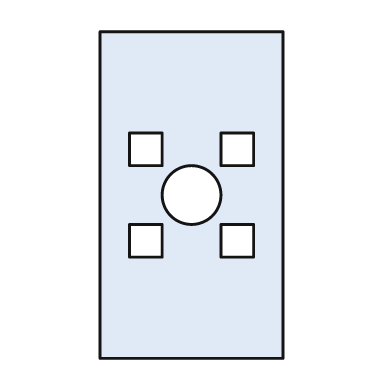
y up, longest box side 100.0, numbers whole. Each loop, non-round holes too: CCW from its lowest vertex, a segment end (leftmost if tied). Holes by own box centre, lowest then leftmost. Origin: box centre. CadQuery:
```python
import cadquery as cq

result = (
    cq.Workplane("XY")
    .moveTo(-28.0, -50.0)
    .lineTo(28.0, -50.0)
    .lineTo(28.0, 50.0)
    .lineTo(-28.0, 50.0)
    .close()
    .moveTo(-19.0, -19.0)
    .lineTo(-9.0, -19.0)
    .lineTo(-9.0, -9.0)
    .lineTo(-19.0, -9.0)
    .close()
    .moveTo(9.0, -19.0)
    .lineTo(19.0, -19.0)
    .lineTo(19.0, -9.0)
    .lineTo(9.0, -9.0)
    .close()
    .moveTo(0.0, 0.0)
    .circle(9.0)
    .moveTo(-19.0, 9.0)
    .lineTo(-9.0, 9.0)
    .lineTo(-9.0, 19.0)
    .lineTo(-19.0, 19.0)
    .close()
    .moveTo(9.0, 9.0)
    .lineTo(19.0, 9.0)
    .lineTo(19.0, 19.0)
    .lineTo(9.0, 19.0)
    .close()
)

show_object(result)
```